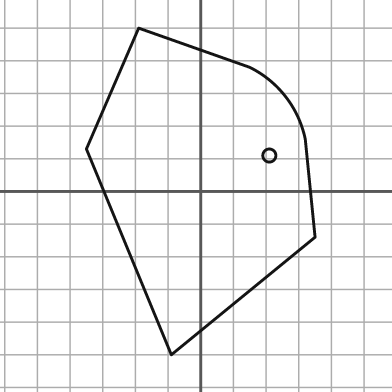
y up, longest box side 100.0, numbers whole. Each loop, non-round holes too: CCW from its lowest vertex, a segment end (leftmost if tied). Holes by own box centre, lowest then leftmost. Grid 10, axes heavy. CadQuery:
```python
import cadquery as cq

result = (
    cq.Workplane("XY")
    .moveTo(-9.0, -50.0)
    .lineTo(35.0, -14.0)
    .lineTo(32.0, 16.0)
    .threePointArc((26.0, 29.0), (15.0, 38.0))
    .lineTo(-19.0, 50.0)
    .lineTo(-35.0, 13.0)
    .close()
    .moveTo(21.0, 11.0)
    .circle(2.0)
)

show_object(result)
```